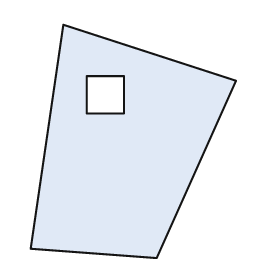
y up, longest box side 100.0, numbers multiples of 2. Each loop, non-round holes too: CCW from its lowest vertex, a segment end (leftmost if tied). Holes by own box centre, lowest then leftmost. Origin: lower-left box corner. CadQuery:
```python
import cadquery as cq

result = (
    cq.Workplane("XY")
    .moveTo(54.0, 0.0)
    .lineTo(88.0, 76.0)
    .lineTo(14.0, 100.0)
    .lineTo(0.0, 4.0)
    .close()
    .moveTo(24.0, 62.0)
    .lineTo(40.0, 62.0)
    .lineTo(40.0, 78.0)
    .lineTo(24.0, 78.0)
    .close()
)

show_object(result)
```